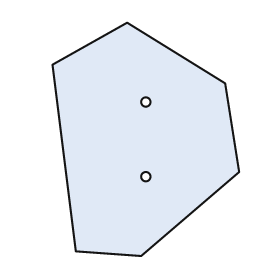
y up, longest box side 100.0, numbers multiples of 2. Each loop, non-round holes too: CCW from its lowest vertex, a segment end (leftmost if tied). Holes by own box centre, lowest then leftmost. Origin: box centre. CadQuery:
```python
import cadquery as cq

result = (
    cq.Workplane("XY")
    .moveTo(-2.0, -50.0)
    .lineTo(40.0, -14.0)
    .lineTo(34.0, 24.0)
    .lineTo(-8.0, 50.0)
    .lineTo(-40.0, 32.0)
    .lineTo(-30.0, -48.0)
    .close()
    .moveTo(0.0, -16.0)
    .circle(2.0)
    .moveTo(0.0, 16.0)
    .circle(2.0)
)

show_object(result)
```